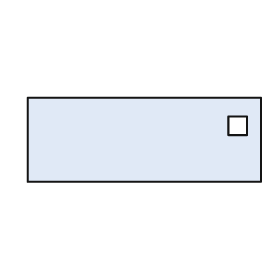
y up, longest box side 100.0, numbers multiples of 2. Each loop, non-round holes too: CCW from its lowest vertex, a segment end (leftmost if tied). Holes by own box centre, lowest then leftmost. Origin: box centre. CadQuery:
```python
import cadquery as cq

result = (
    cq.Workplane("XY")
    .moveTo(-50.0, -18.0)
    .lineTo(50.0, -18.0)
    .lineTo(50.0, 18.0)
    .lineTo(-50.0, 18.0)
    .close()
    .moveTo(36.0, 2.0)
    .lineTo(44.0, 2.0)
    .lineTo(44.0, 10.0)
    .lineTo(36.0, 10.0)
    .close()
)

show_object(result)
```